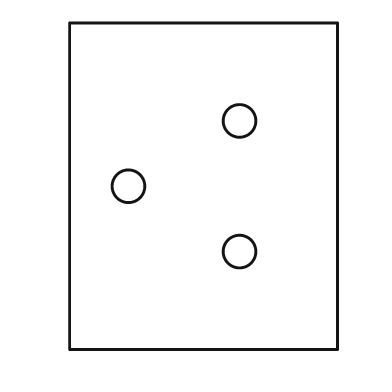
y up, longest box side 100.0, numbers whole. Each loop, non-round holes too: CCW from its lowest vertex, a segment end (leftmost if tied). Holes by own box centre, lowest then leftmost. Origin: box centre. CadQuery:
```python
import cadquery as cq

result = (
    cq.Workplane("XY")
    .moveTo(-41.0, -50.0)
    .lineTo(41.0, -50.0)
    .lineTo(41.0, 50.0)
    .lineTo(-41.0, 50.0)
    .close()
    .moveTo(11.0, -20.0)
    .circle(5.0)
    .moveTo(-23.0, 0.0)
    .circle(5.0)
    .moveTo(11.0, 20.0)
    .circle(5.0)
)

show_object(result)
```